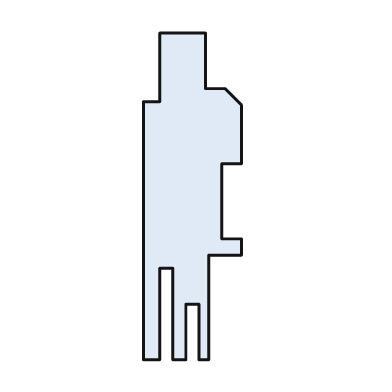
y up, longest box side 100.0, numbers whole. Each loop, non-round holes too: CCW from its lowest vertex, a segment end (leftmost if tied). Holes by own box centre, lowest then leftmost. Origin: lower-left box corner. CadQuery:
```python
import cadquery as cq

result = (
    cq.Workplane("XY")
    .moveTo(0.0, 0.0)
    .lineTo(5.0, 0.0)
    .lineTo(5.0, 28.0)
    .lineTo(9.0, 28.0)
    .lineTo(9.0, 0.0)
    .lineTo(13.0, 0.0)
    .lineTo(13.0, 17.0)
    .lineTo(17.0, 17.0)
    .lineTo(17.0, 0.0)
    .lineTo(20.0, 0.0)
    .lineTo(20.0, 32.0)
    .lineTo(30.0, 32.0)
    .lineTo(30.0, 37.0)
    .lineTo(24.0, 37.0)
    .lineTo(24.0, 60.0)
    .lineTo(30.0, 60.0)
    .lineTo(30.0, 78.0)
    .lineTo(25.0, 83.0)
    .lineTo(19.0, 83.0)
    .lineTo(19.0, 100.0)
    .lineTo(5.0, 100.0)
    .lineTo(5.0, 79.0)
    .lineTo(0.0, 79.0)
    .close()
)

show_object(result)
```